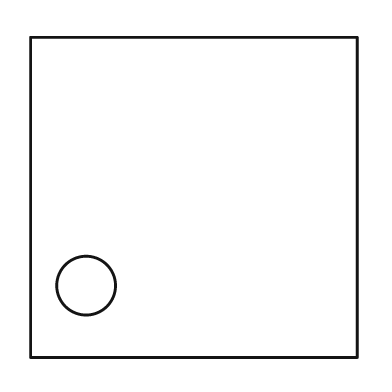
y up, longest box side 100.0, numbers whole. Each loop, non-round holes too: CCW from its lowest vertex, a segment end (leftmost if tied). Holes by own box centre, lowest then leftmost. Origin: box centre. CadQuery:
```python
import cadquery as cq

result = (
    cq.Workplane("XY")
    .moveTo(-50.0, -49.0)
    .lineTo(50.0, -49.0)
    .lineTo(50.0, 49.0)
    .lineTo(-50.0, 49.0)
    .close()
    .moveTo(-33.0, -27.0)
    .circle(9.0)
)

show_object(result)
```